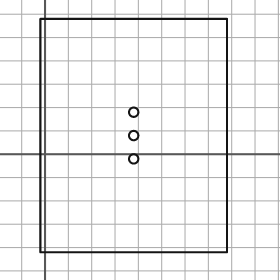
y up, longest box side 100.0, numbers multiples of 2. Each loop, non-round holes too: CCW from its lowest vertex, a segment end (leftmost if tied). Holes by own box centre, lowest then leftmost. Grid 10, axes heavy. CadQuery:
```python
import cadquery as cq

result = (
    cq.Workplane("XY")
    .moveTo(-2.0, -42.0)
    .lineTo(78.0, -42.0)
    .lineTo(78.0, 58.0)
    .lineTo(-2.0, 58.0)
    .close()
    .moveTo(38.0, -2.0)
    .circle(2.0)
    .moveTo(38.0, 8.0)
    .circle(2.0)
    .moveTo(38.0, 18.0)
    .circle(2.0)
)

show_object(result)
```